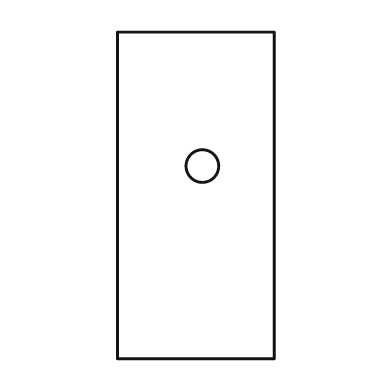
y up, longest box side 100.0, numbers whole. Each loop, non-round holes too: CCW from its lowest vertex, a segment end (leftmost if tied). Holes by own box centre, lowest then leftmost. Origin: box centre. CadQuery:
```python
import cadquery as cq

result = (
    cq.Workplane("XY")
    .moveTo(-24.0, -50.0)
    .lineTo(24.0, -50.0)
    .lineTo(24.0, 50.0)
    .lineTo(-24.0, 50.0)
    .close()
    .moveTo(2.0, 9.0)
    .circle(5.0)
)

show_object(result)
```